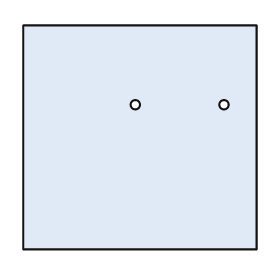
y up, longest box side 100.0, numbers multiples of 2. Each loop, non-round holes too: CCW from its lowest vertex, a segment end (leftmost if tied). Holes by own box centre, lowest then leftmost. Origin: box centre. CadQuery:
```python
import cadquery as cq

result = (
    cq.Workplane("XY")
    .moveTo(-50.0, -48.0)
    .lineTo(50.0, -48.0)
    .lineTo(50.0, 48.0)
    .lineTo(-50.0, 48.0)
    .close()
    .moveTo(-2.0, 14.0)
    .circle(2.0)
    .moveTo(36.0, 14.0)
    .circle(2.0)
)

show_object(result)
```